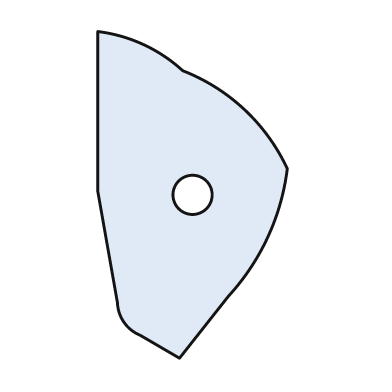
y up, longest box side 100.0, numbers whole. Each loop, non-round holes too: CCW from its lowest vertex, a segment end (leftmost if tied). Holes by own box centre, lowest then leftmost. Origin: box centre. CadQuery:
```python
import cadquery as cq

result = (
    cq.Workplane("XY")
    .moveTo(-4.0, -50.0)
    .lineTo(11.0, -31.0)
    .threePointArc((23.0, -13.0), (29.0, 8.0))
    .threePointArc((16.0, 26.0), (-3.0, 38.0))
    .threePointArc((-15.0, 46.0), (-29.0, 50.0))
    .lineTo(-29.0, 1.0)
    .lineTo(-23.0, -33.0)
    .threePointArc((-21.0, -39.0), (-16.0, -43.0))
    .close()
    .moveTo(0.0, 0.0)
    .circle(6.0)
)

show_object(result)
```